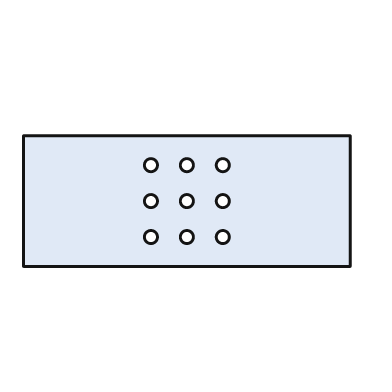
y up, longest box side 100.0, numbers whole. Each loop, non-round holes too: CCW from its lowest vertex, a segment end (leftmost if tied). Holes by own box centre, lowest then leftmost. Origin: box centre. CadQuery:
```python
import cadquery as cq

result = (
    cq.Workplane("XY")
    .moveTo(-50.0, -20.0)
    .lineTo(50.0, -20.0)
    .lineTo(50.0, 20.0)
    .lineTo(-50.0, 20.0)
    .close()
    .moveTo(-11.0, -11.0)
    .circle(2.0)
    .moveTo(0.0, -11.0)
    .circle(2.0)
    .moveTo(11.0, -11.0)
    .circle(2.0)
    .moveTo(-11.0, 0.0)
    .circle(2.0)
    .moveTo(0.0, 0.0)
    .circle(2.0)
    .moveTo(11.0, 0.0)
    .circle(2.0)
    .moveTo(-11.0, 11.0)
    .circle(2.0)
    .moveTo(0.0, 11.0)
    .circle(2.0)
    .moveTo(11.0, 11.0)
    .circle(2.0)
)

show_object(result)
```